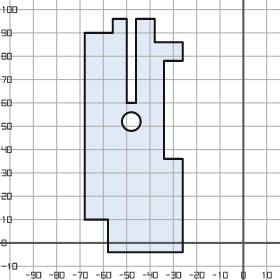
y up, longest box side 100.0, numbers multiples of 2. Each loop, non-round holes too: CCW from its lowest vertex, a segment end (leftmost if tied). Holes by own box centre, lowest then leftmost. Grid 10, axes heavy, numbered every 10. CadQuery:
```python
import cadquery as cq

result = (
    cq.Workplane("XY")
    .moveTo(-58.0, -4.0)
    .lineTo(-26.0, -4.0)
    .lineTo(-26.0, 36.0)
    .lineTo(-34.0, 36.0)
    .lineTo(-34.0, 78.0)
    .lineTo(-26.0, 78.0)
    .lineTo(-26.0, 86.0)
    .lineTo(-38.0, 86.0)
    .lineTo(-38.0, 96.0)
    .lineTo(-46.0, 96.0)
    .lineTo(-46.0, 60.0)
    .lineTo(-50.0, 60.0)
    .lineTo(-50.0, 96.0)
    .lineTo(-56.0, 96.0)
    .lineTo(-56.0, 90.0)
    .lineTo(-68.0, 90.0)
    .lineTo(-68.0, 10.0)
    .lineTo(-58.0, 10.0)
    .close()
    .moveTo(-48.0, 52.0)
    .circle(4.0)
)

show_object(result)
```